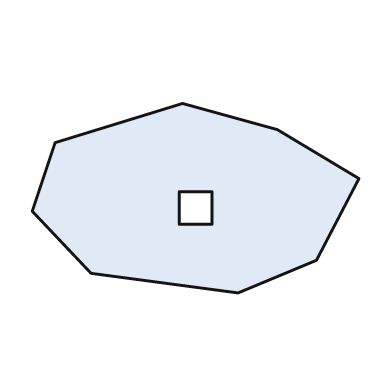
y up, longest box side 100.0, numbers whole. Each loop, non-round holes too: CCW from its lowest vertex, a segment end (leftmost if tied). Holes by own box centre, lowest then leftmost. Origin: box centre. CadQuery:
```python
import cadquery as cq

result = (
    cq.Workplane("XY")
    .moveTo(13.0, -29.0)
    .lineTo(37.0, -19.0)
    .lineTo(50.0, 6.0)
    .lineTo(25.0, 21.0)
    .lineTo(-4.0, 29.0)
    .lineTo(-43.0, 17.0)
    .lineTo(-50.0, -4.0)
    .lineTo(-32.0, -23.0)
    .close()
    .moveTo(-5.0, -8.0)
    .lineTo(5.0, -8.0)
    .lineTo(5.0, 2.0)
    .lineTo(-5.0, 2.0)
    .close()
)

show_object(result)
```